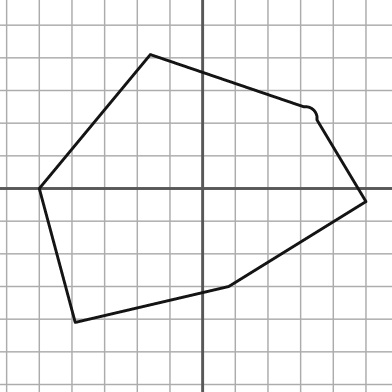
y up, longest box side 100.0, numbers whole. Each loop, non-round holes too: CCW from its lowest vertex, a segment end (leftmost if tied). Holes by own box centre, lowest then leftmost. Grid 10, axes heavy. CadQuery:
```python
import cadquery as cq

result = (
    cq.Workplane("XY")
    .moveTo(-39.0, -41.0)
    .lineTo(8.0, -30.0)
    .lineTo(50.0, -4.0)
    .lineTo(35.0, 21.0)
    .threePointArc((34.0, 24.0), (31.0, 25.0))
    .lineTo(-16.0, 41.0)
    .lineTo(-50.0, 0.0)
    .close()
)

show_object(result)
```